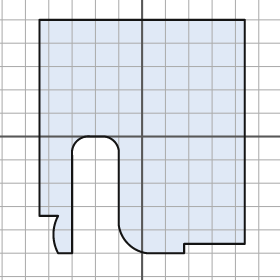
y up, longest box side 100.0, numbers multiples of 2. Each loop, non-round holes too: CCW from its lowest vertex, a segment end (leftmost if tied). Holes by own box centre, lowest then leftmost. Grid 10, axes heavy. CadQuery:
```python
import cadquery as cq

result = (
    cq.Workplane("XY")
    .moveTo(-36.0, -50.0)
    .lineTo(-30.0, -50.0)
    .lineTo(-30.0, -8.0)
    .threePointArc((-28.0, -2.0), (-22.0, 0.0))
    .lineTo(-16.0, 0.0)
    .threePointArc((-12.0, -2.0), (-10.0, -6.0))
    .lineTo(-10.0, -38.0)
    .threePointArc((-6.0, -46.0), (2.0, -50.0))
    .lineTo(18.0, -50.0)
    .lineTo(18.0, -46.0)
    .lineTo(44.0, -46.0)
    .lineTo(44.0, 50.0)
    .lineTo(-44.0, 50.0)
    .lineTo(-44.0, -34.0)
    .lineTo(-36.0, -34.0)
    .threePointArc((-38.0, -42.0), (-36.0, -50.0))
    .close()
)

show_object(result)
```